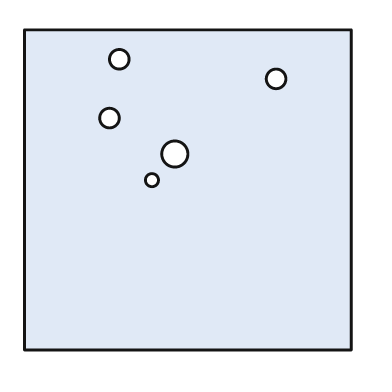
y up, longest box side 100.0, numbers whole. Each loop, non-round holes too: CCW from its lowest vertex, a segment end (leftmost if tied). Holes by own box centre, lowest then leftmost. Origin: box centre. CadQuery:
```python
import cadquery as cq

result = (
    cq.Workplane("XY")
    .moveTo(-50.0, -49.0)
    .lineTo(50.0, -49.0)
    .lineTo(50.0, 49.0)
    .lineTo(-50.0, 49.0)
    .close()
    .moveTo(-11.0, 3.0)
    .circle(2.0)
    .moveTo(-4.0, 11.0)
    .circle(4.0)
    .moveTo(-24.0, 22.0)
    .circle(3.0)
    .moveTo(27.0, 34.0)
    .circle(3.0)
    .moveTo(-21.0, 40.0)
    .circle(3.0)
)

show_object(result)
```